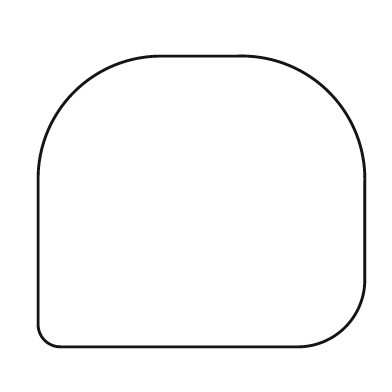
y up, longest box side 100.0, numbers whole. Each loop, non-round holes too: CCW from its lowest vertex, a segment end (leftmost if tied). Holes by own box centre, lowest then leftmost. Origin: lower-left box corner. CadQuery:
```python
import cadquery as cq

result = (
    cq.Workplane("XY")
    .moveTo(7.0, 0.0)
    .lineTo(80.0, 0.0)
    .threePointArc((94.0, 6.0), (100.0, 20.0))
    .lineTo(100.0, 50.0)
    .threePointArc((89.0, 78.0), (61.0, 89.0))
    .lineTo(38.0, 89.0)
    .threePointArc((11.0, 78.0), (0.0, 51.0))
    .lineTo(0.0, 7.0)
    .threePointArc((2.0, 2.0), (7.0, 0.0))
    .close()
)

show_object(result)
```